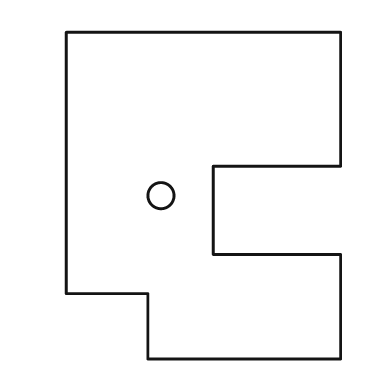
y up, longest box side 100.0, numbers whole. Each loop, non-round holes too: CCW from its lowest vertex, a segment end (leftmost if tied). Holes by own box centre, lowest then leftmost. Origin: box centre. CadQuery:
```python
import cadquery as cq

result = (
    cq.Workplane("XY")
    .moveTo(-17.0, -50.0)
    .lineTo(42.0, -50.0)
    .lineTo(42.0, -18.0)
    .lineTo(3.0, -18.0)
    .lineTo(3.0, 9.0)
    .lineTo(42.0, 9.0)
    .lineTo(42.0, 50.0)
    .lineTo(-42.0, 50.0)
    .lineTo(-42.0, -30.0)
    .lineTo(-17.0, -30.0)
    .close()
    .moveTo(-13.0, 0.0)
    .circle(4.0)
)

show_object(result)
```